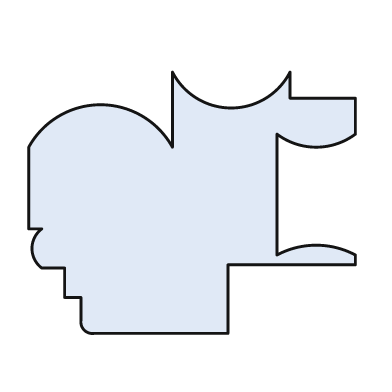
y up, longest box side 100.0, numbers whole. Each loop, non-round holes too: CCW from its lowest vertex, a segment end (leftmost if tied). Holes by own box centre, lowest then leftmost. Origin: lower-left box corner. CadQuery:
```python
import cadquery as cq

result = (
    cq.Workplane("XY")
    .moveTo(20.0, 0.0)
    .lineTo(61.0, 0.0)
    .lineTo(61.0, 21.0)
    .lineTo(100.0, 21.0)
    .lineTo(100.0, 24.0)
    .threePointArc((88.0, 27.0), (76.0, 24.0))
    .lineTo(76.0, 61.0)
    .threePointArc((88.0, 57.0), (100.0, 61.0))
    .lineTo(100.0, 72.0)
    .lineTo(80.0, 72.0)
    .lineTo(80.0, 80.0)
    .threePointArc((62.0, 69.0), (44.0, 80.0))
    .lineTo(44.0, 57.0)
    .threePointArc((22.0, 70.0), (0.0, 57.0))
    .lineTo(0.0, 32.0)
    .lineTo(4.0, 32.0)
    .threePointArc((1.0, 26.0), (4.0, 20.0))
    .lineTo(11.0, 20.0)
    .lineTo(11.0, 11.0)
    .lineTo(16.0, 11.0)
    .lineTo(16.0, 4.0)
    .threePointArc((17.0, 1.0), (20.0, 0.0))
    .close()
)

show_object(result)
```